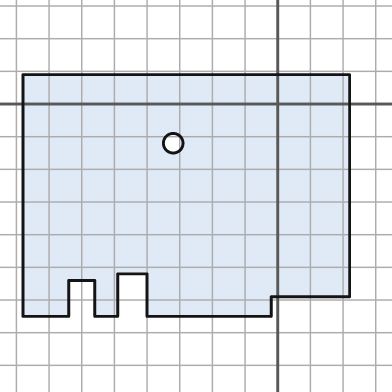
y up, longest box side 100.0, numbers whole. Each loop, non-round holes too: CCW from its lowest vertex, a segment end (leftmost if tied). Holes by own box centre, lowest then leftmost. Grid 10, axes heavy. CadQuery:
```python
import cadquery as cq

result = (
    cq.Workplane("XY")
    .moveTo(-78.0, -65.0)
    .lineTo(-64.0, -65.0)
    .lineTo(-64.0, -54.0)
    .lineTo(-56.0, -54.0)
    .lineTo(-56.0, -65.0)
    .lineTo(-49.0, -65.0)
    .lineTo(-49.0, -52.0)
    .lineTo(-40.0, -52.0)
    .lineTo(-40.0, -65.0)
    .lineTo(-2.0, -65.0)
    .lineTo(-2.0, -59.0)
    .lineTo(22.0, -59.0)
    .lineTo(22.0, 9.0)
    .lineTo(-78.0, 9.0)
    .close()
    .moveTo(-32.0, -12.0)
    .circle(3.0)
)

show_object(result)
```